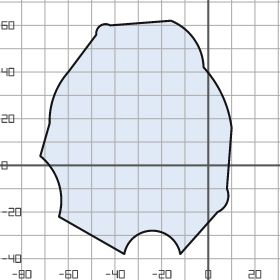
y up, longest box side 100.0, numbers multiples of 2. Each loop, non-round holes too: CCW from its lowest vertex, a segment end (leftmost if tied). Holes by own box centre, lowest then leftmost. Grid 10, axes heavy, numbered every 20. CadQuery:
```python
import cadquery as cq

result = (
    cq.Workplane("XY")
    .moveTo(-36.0, -38.0)
    .threePointArc((-24.0, -28.0), (-12.0, -38.0))
    .lineTo(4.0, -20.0)
    .threePointArc((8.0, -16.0), (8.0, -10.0))
    .lineTo(10.0, 16.0)
    .threePointArc((6.0, 30.0), (-2.0, 42.0))
    .threePointArc((-6.0, 54.0), (-16.0, 62.0))
    .lineTo(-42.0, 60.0)
    .threePointArc((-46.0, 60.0), (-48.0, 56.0))
    .lineTo(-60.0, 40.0)
    .threePointArc((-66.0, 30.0), (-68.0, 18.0))
    .lineTo(-72.0, 4.0)
    .threePointArc((-64.0, -8.0), (-64.0, -22.0))
    .close()
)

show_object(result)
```